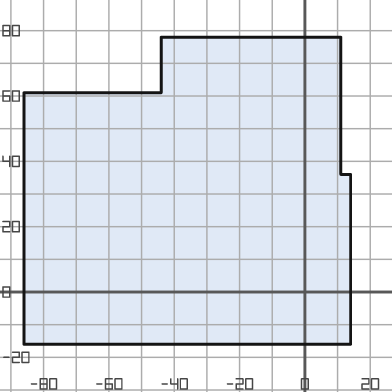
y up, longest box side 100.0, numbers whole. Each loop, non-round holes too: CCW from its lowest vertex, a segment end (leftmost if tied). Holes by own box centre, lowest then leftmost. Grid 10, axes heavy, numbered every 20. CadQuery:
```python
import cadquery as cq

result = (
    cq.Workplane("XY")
    .moveTo(-86.0, -16.0)
    .lineTo(14.0, -16.0)
    .lineTo(14.0, 36.0)
    .lineTo(11.0, 36.0)
    .lineTo(11.0, 78.0)
    .lineTo(-44.0, 78.0)
    .lineTo(-44.0, 61.0)
    .lineTo(-86.0, 61.0)
    .close()
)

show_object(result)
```